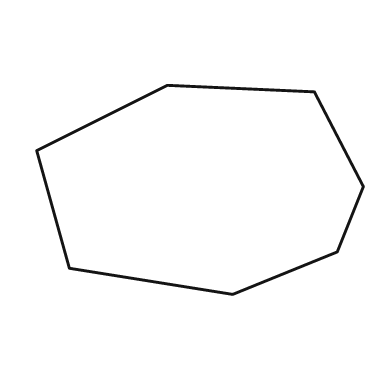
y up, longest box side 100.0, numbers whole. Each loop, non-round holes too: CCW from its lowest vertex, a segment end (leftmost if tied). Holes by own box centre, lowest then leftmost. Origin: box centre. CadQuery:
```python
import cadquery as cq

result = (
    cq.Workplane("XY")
    .moveTo(10.0, -32.0)
    .lineTo(42.0, -19.0)
    .lineTo(50.0, 1.0)
    .lineTo(35.0, 30.0)
    .lineTo(-10.0, 32.0)
    .lineTo(-50.0, 12.0)
    .lineTo(-40.0, -24.0)
    .close()
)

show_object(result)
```